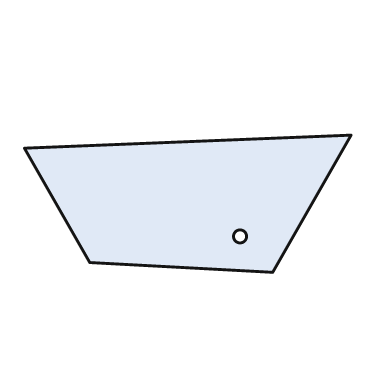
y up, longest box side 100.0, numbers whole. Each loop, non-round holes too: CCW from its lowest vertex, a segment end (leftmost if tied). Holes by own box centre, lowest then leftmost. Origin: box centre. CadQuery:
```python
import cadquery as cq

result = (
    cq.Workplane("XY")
    .moveTo(26.0, -21.0)
    .lineTo(50.0, 21.0)
    .lineTo(-50.0, 17.0)
    .lineTo(-30.0, -18.0)
    .close()
    .moveTo(16.0, -10.0)
    .circle(2.0)
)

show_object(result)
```